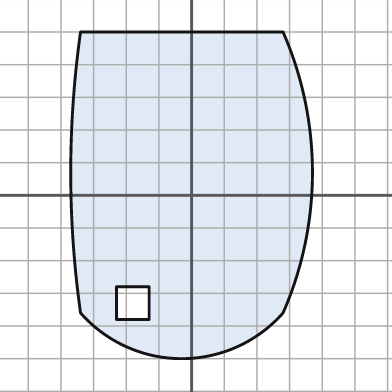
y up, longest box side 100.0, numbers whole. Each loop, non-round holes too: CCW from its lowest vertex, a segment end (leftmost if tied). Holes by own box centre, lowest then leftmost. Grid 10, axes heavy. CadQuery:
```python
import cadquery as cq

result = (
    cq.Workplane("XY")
    .moveTo(-34.0, -36.0)
    .threePointArc((-3.0, -50.0), (28.0, -36.0))
    .threePointArc((37.0, 7.0), (28.0, 50.0))
    .lineTo(-34.0, 50.0)
    .threePointArc((-37.0, 7.0), (-34.0, -36.0))
    .close()
    .moveTo(-23.0, -38.0)
    .lineTo(-13.0, -38.0)
    .lineTo(-13.0, -28.0)
    .lineTo(-23.0, -28.0)
    .close()
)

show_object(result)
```